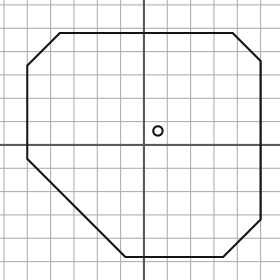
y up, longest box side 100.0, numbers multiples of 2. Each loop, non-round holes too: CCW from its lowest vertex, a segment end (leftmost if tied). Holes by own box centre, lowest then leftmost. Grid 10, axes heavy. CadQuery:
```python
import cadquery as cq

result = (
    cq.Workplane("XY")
    .moveTo(-8.0, -48.0)
    .lineTo(34.0, -48.0)
    .lineTo(50.0, -32.0)
    .lineTo(50.0, 36.0)
    .lineTo(38.0, 48.0)
    .lineTo(-36.0, 48.0)
    .lineTo(-50.0, 34.0)
    .lineTo(-50.0, -6.0)
    .close()
    .moveTo(6.0, 6.0)
    .circle(2.0)
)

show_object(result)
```